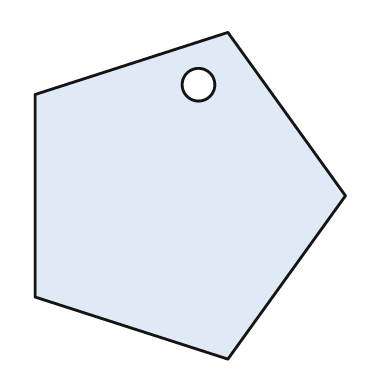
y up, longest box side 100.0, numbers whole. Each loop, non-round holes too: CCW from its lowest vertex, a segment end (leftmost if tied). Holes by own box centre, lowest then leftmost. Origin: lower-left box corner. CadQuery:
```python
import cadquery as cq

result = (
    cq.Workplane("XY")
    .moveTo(59.0, 0.0)
    .lineTo(95.0, 50.0)
    .lineTo(59.0, 100.0)
    .lineTo(0.0, 81.0)
    .lineTo(0.0, 19.0)
    .close()
    .moveTo(50.0, 84.0)
    .circle(5.0)
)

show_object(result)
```